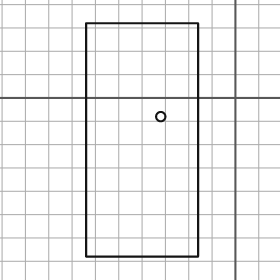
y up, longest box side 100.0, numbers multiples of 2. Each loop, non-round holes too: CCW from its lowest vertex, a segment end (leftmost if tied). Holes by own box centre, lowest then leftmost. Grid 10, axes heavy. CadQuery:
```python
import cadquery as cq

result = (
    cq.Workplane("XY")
    .moveTo(-64.0, -68.0)
    .lineTo(-16.0, -68.0)
    .lineTo(-16.0, 32.0)
    .lineTo(-64.0, 32.0)
    .close()
    .moveTo(-32.0, -8.0)
    .circle(2.0)
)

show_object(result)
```